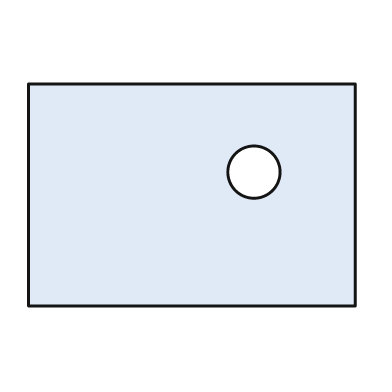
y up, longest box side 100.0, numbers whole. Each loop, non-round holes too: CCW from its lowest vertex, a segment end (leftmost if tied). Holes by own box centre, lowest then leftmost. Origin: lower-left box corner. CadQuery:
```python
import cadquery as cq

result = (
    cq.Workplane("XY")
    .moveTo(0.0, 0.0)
    .lineTo(100.0, 0.0)
    .lineTo(100.0, 68.0)
    .lineTo(0.0, 68.0)
    .close()
    .moveTo(69.0, 41.0)
    .circle(8.0)
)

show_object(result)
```